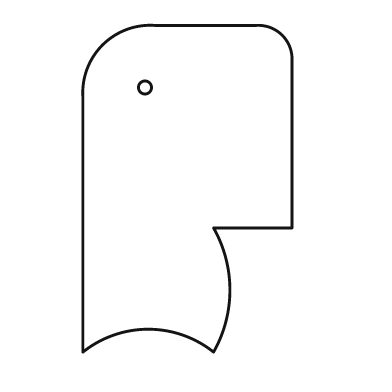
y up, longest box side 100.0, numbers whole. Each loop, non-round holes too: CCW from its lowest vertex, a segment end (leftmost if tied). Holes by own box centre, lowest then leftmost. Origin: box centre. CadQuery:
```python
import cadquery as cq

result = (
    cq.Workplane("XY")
    .moveTo(-32.0, -50.0)
    .threePointArc((-12.0, -43.0), (8.0, -50.0))
    .threePointArc((13.0, -31.0), (8.0, -12.0))
    .lineTo(32.0, -12.0)
    .lineTo(32.0, 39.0)
    .threePointArc((29.0, 47.0), (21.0, 50.0))
    .lineTo(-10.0, 50.0)
    .threePointArc((-26.0, 44.0), (-32.0, 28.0))
    .close()
    .moveTo(-13.0, 31.0)
    .circle(2.0)
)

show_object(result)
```